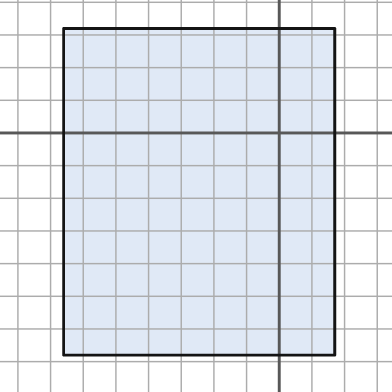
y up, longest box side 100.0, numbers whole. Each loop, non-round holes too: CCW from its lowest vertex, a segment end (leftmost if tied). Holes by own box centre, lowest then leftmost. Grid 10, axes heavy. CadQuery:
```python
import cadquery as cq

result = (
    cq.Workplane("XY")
    .moveTo(-66.0, -68.0)
    .lineTo(17.0, -68.0)
    .lineTo(17.0, 32.0)
    .lineTo(-66.0, 32.0)
    .close()
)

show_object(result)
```